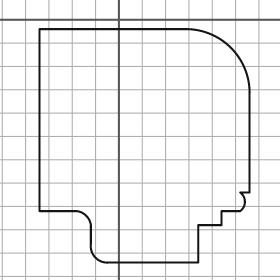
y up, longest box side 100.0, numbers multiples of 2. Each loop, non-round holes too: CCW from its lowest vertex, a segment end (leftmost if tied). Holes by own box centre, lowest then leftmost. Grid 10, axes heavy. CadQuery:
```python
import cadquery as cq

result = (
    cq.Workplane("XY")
    .moveTo(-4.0, -104.0)
    .lineTo(34.0, -104.0)
    .lineTo(34.0, -88.0)
    .lineTo(44.0, -88.0)
    .lineTo(44.0, -82.0)
    .lineTo(52.0, -82.0)
    .threePointArc((54.0, -78.0), (52.0, -74.0))
    .lineTo(56.0, -74.0)
    .lineTo(56.0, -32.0)
    .threePointArc((48.0, -12.0), (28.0, -4.0))
    .lineTo(-34.0, -4.0)
    .lineTo(-34.0, -82.0)
    .lineTo(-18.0, -82.0)
    .threePointArc((-14.0, -84.0), (-12.0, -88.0))
    .lineTo(-12.0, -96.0)
    .threePointArc((-10.0, -102.0), (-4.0, -104.0))
    .close()
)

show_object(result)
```